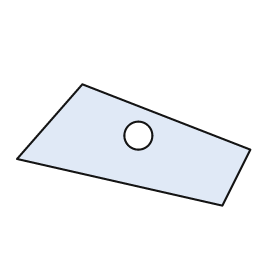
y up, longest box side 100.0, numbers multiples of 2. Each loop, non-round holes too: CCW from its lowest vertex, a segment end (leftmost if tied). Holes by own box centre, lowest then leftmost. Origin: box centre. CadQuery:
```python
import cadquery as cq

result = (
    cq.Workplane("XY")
    .moveTo(38.0, -26.0)
    .lineTo(50.0, -2.0)
    .lineTo(-22.0, 26.0)
    .lineTo(-50.0, -6.0)
    .close()
    .moveTo(2.0, 4.0)
    .circle(6.0)
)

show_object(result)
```